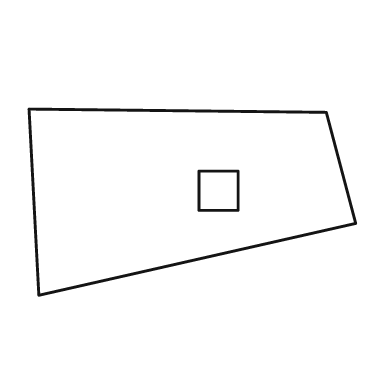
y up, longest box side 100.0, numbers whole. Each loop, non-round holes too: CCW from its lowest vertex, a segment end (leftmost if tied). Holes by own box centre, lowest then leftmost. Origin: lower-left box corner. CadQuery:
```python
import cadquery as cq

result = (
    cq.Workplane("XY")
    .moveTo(3.0, 0.0)
    .lineTo(100.0, 22.0)
    .lineTo(91.0, 56.0)
    .lineTo(0.0, 57.0)
    .close()
    .moveTo(52.0, 26.0)
    .lineTo(64.0, 26.0)
    .lineTo(64.0, 38.0)
    .lineTo(52.0, 38.0)
    .close()
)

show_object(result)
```